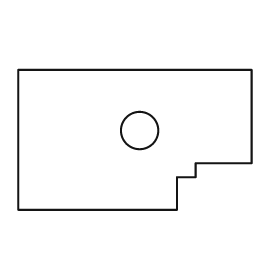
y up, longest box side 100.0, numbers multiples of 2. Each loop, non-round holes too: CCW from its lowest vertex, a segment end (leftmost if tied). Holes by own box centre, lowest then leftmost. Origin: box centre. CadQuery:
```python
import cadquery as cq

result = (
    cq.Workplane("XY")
    .moveTo(-50.0, -30.0)
    .lineTo(18.0, -30.0)
    .lineTo(18.0, -16.0)
    .lineTo(26.0, -16.0)
    .lineTo(26.0, -10.0)
    .lineTo(50.0, -10.0)
    .lineTo(50.0, 30.0)
    .lineTo(-50.0, 30.0)
    .close()
    .moveTo(2.0, 4.0)
    .circle(8.0)
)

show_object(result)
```